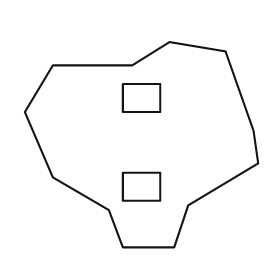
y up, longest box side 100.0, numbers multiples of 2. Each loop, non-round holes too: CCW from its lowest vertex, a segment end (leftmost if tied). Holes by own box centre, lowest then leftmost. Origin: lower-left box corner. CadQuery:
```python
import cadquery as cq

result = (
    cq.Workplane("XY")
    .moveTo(42.0, 0.0)
    .lineTo(64.0, 0.0)
    .lineTo(70.0, 18.0)
    .lineTo(100.0, 36.0)
    .lineTo(98.0, 50.0)
    .lineTo(86.0, 84.0)
    .lineTo(62.0, 88.0)
    .lineTo(46.0, 78.0)
    .lineTo(12.0, 78.0)
    .lineTo(0.0, 58.0)
    .lineTo(12.0, 30.0)
    .lineTo(36.0, 16.0)
    .close()
    .moveTo(42.0, 20.0)
    .lineTo(58.0, 20.0)
    .lineTo(58.0, 32.0)
    .lineTo(42.0, 32.0)
    .close()
    .moveTo(42.0, 58.0)
    .lineTo(58.0, 58.0)
    .lineTo(58.0, 70.0)
    .lineTo(42.0, 70.0)
    .close()
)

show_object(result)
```